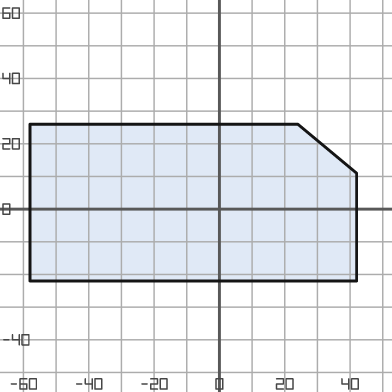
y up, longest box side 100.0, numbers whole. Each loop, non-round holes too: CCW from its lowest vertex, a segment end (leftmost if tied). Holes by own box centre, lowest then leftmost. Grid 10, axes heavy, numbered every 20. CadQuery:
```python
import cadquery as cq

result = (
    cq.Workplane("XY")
    .moveTo(-58.0, -22.0)
    .lineTo(42.0, -22.0)
    .lineTo(42.0, 11.0)
    .lineTo(24.0, 26.0)
    .lineTo(-58.0, 26.0)
    .close()
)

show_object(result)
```